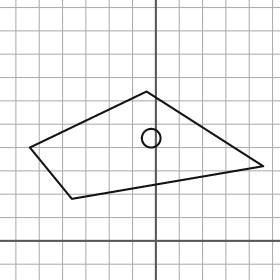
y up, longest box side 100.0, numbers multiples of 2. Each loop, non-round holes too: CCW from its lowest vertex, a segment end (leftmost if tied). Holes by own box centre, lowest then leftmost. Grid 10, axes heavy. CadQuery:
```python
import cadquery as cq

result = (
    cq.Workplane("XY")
    .moveTo(-36.0, 18.0)
    .lineTo(46.0, 32.0)
    .lineTo(-4.0, 64.0)
    .lineTo(-54.0, 40.0)
    .close()
    .moveTo(-2.0, 44.0)
    .circle(4.0)
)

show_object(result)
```